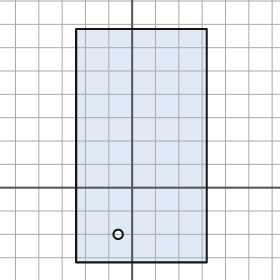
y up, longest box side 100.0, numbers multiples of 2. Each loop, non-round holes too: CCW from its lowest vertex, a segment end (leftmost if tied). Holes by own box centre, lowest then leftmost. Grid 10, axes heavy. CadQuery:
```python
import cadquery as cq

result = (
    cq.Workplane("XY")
    .moveTo(-24.0, -32.0)
    .lineTo(32.0, -32.0)
    .lineTo(32.0, 68.0)
    .lineTo(-24.0, 68.0)
    .close()
    .moveTo(-6.0, -20.0)
    .circle(2.0)
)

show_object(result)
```